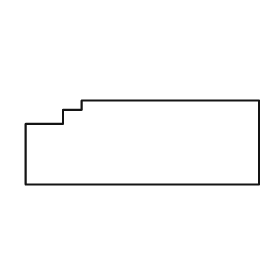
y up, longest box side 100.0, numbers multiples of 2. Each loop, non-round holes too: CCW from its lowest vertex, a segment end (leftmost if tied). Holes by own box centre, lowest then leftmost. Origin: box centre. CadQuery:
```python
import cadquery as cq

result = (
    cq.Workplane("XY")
    .moveTo(-50.0, -18.0)
    .lineTo(50.0, -18.0)
    .lineTo(50.0, 18.0)
    .lineTo(-26.0, 18.0)
    .lineTo(-26.0, 14.0)
    .lineTo(-34.0, 14.0)
    .lineTo(-34.0, 8.0)
    .lineTo(-50.0, 8.0)
    .close()
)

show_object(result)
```